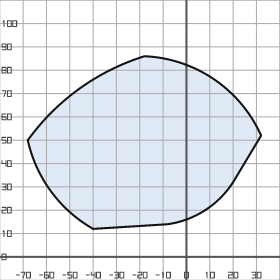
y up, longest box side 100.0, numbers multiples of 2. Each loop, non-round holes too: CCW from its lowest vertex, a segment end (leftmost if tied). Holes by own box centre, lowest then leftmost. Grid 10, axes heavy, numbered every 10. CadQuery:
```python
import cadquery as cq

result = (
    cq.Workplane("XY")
    .moveTo(-40.0, 12.0)
    .lineTo(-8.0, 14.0)
    .threePointArc((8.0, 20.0), (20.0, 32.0))
    .lineTo(32.0, 52.0)
    .threePointArc((12.0, 76.0), (-18.0, 86.0))
    .threePointArc((-46.0, 72.0), (-68.0, 50.0))
    .threePointArc((-58.0, 28.0), (-40.0, 12.0))
    .close()
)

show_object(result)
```